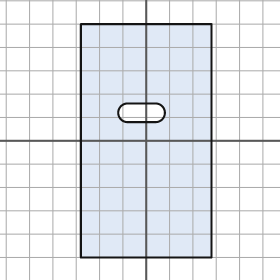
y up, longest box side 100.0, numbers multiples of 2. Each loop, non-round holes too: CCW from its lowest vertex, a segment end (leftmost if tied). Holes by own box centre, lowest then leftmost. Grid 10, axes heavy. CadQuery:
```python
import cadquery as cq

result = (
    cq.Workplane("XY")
    .moveTo(-28.0, -50.0)
    .lineTo(28.0, -50.0)
    .lineTo(28.0, 50.0)
    .lineTo(-28.0, 50.0)
    .close()
    .moveTo(-8.0, 8.0)
    .lineTo(4.0, 8.0)
    .threePointArc((8.0, 12.0), (4.0, 16.0))
    .lineTo(-8.0, 16.0)
    .threePointArc((-12.0, 12.0), (-8.0, 8.0))
    .close()
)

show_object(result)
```